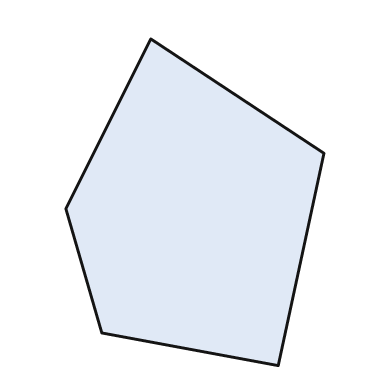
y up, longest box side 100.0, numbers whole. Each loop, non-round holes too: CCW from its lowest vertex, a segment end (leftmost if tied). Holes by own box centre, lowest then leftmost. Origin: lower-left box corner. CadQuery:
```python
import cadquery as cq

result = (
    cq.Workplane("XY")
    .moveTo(65.0, 0.0)
    .lineTo(79.0, 65.0)
    .lineTo(26.0, 100.0)
    .lineTo(0.0, 48.0)
    .lineTo(11.0, 10.0)
    .close()
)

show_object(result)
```